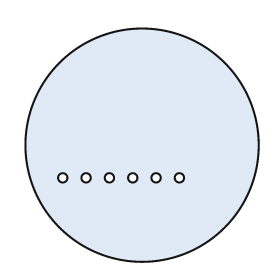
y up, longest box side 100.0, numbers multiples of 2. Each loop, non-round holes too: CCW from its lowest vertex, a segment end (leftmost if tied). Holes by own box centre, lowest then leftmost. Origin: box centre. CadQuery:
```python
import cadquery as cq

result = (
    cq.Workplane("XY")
    .moveTo(0.0, 0.0)
    .circle(50.0)
    .moveTo(-34.0, -14.0)
    .circle(2.0)
    .moveTo(-24.0, -14.0)
    .circle(2.0)
    .moveTo(-14.0, -14.0)
    .circle(2.0)
    .moveTo(-4.0, -14.0)
    .circle(2.0)
    .moveTo(6.0, -14.0)
    .circle(2.0)
    .moveTo(16.0, -14.0)
    .circle(2.0)
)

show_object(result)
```